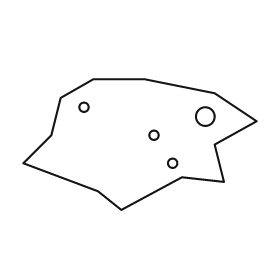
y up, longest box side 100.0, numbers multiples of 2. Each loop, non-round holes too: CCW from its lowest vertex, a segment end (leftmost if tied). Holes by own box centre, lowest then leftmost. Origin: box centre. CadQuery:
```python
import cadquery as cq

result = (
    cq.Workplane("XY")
    .moveTo(-8.0, -28.0)
    .lineTo(18.0, -14.0)
    .lineTo(36.0, -16.0)
    .lineTo(32.0, 0.0)
    .lineTo(50.0, 10.0)
    .lineTo(32.0, 22.0)
    .lineTo(2.0, 28.0)
    .lineTo(-20.0, 28.0)
    .lineTo(-34.0, 20.0)
    .lineTo(-38.0, 4.0)
    .lineTo(-50.0, -8.0)
    .lineTo(-18.0, -20.0)
    .close()
    .moveTo(14.0, -8.0)
    .circle(2.0)
    .moveTo(6.0, 4.0)
    .circle(2.0)
    .moveTo(28.0, 12.0)
    .circle(4.0)
    .moveTo(-24.0, 16.0)
    .circle(2.0)
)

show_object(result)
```